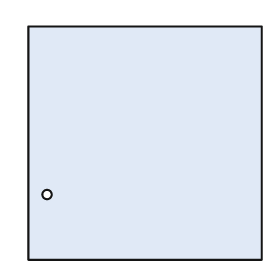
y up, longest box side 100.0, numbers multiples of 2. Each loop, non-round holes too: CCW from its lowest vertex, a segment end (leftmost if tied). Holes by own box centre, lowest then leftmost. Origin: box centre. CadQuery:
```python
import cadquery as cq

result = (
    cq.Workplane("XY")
    .moveTo(-50.0, -50.0)
    .lineTo(50.0, -50.0)
    .lineTo(50.0, 50.0)
    .lineTo(-50.0, 50.0)
    .close()
    .moveTo(-42.0, -22.0)
    .circle(2.0)
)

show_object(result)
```